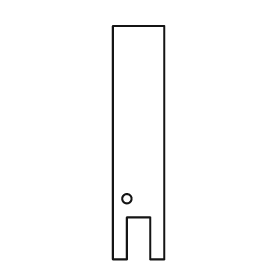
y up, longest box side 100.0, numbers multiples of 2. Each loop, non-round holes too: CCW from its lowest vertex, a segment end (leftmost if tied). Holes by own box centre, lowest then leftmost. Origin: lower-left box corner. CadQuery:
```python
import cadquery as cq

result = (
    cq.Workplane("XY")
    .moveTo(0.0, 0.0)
    .lineTo(6.0, 0.0)
    .lineTo(6.0, 18.0)
    .lineTo(16.0, 18.0)
    .lineTo(16.0, 0.0)
    .lineTo(22.0, 0.0)
    .lineTo(22.0, 100.0)
    .lineTo(0.0, 100.0)
    .close()
    .moveTo(6.0, 26.0)
    .circle(2.0)
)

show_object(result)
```